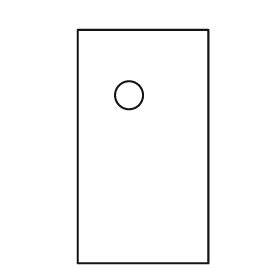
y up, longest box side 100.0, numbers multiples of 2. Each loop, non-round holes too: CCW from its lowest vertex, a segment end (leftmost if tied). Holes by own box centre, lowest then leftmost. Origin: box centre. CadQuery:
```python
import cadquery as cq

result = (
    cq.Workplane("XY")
    .moveTo(-28.0, -50.0)
    .lineTo(28.0, -50.0)
    .lineTo(28.0, 50.0)
    .lineTo(-28.0, 50.0)
    .close()
    .moveTo(-6.0, 22.0)
    .circle(6.0)
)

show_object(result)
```